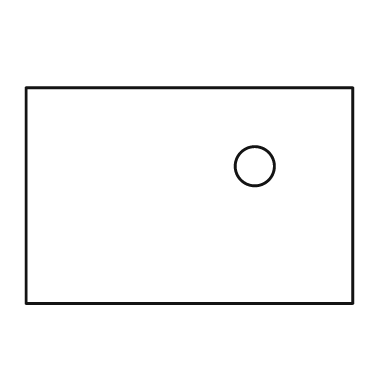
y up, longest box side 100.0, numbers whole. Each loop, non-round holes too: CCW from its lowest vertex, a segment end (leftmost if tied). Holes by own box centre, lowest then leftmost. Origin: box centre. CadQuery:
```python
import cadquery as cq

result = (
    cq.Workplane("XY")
    .moveTo(-50.0, -33.0)
    .lineTo(50.0, -33.0)
    .lineTo(50.0, 33.0)
    .lineTo(-50.0, 33.0)
    .close()
    .moveTo(20.0, 9.0)
    .circle(6.0)
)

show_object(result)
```